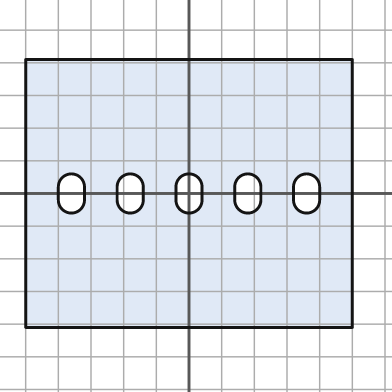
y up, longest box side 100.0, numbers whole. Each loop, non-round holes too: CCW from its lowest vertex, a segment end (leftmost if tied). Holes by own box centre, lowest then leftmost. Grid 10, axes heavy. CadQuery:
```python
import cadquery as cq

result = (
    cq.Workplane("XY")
    .moveTo(-50.0, -41.0)
    .lineTo(50.0, -41.0)
    .lineTo(50.0, 41.0)
    .lineTo(-50.0, 41.0)
    .close()
    .moveTo(-40.0, -2.0)
    .threePointArc((-36.0, -6.0), (-32.0, -2.0))
    .lineTo(-32.0, 2.0)
    .threePointArc((-36.0, 6.0), (-40.0, 2.0))
    .close()
    .moveTo(-22.0, -2.0)
    .threePointArc((-18.0, -6.0), (-14.0, -2.0))
    .lineTo(-14.0, 2.0)
    .threePointArc((-18.0, 6.0), (-22.0, 2.0))
    .close()
    .moveTo(-4.0, -2.0)
    .threePointArc((0.0, -6.0), (4.0, -2.0))
    .lineTo(4.0, 2.0)
    .threePointArc((0.0, 6.0), (-4.0, 2.0))
    .close()
    .moveTo(14.0, -2.0)
    .threePointArc((18.0, -6.0), (22.0, -2.0))
    .lineTo(22.0, 2.0)
    .threePointArc((18.0, 6.0), (14.0, 2.0))
    .close()
    .moveTo(32.0, -2.0)
    .threePointArc((36.0, -6.0), (40.0, -2.0))
    .lineTo(40.0, 2.0)
    .threePointArc((36.0, 6.0), (32.0, 2.0))
    .close()
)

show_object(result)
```